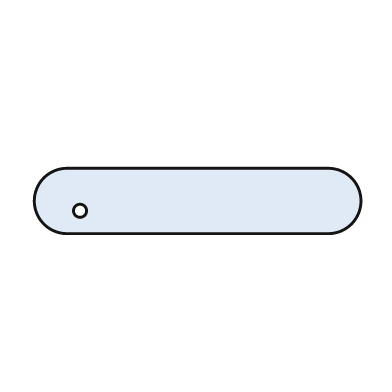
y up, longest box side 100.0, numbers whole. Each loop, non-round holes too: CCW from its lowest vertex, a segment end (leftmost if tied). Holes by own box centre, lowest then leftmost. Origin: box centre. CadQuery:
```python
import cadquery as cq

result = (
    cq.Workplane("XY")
    .moveTo(-40.0, -10.0)
    .lineTo(40.0, -10.0)
    .threePointArc((50.0, 0.0), (40.0, 10.0))
    .lineTo(-40.0, 10.0)
    .threePointArc((-50.0, 0.0), (-40.0, -10.0))
    .close()
    .moveTo(-36.0, -3.0)
    .circle(2.0)
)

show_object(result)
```